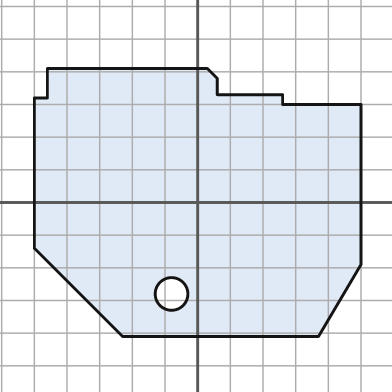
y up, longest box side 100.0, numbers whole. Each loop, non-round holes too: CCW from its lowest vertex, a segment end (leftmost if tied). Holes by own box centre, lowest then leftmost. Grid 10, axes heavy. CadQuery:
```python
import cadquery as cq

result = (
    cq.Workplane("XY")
    .moveTo(-23.0, -41.0)
    .lineTo(37.0, -41.0)
    .lineTo(50.0, -19.0)
    .lineTo(50.0, 30.0)
    .lineTo(26.0, 30.0)
    .lineTo(26.0, 33.0)
    .lineTo(6.0, 33.0)
    .lineTo(6.0, 38.0)
    .lineTo(3.0, 41.0)
    .lineTo(-46.0, 41.0)
    .lineTo(-46.0, 32.0)
    .lineTo(-50.0, 32.0)
    .lineTo(-50.0, -14.0)
    .close()
    .moveTo(-8.0, -28.0)
    .circle(5.0)
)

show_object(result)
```